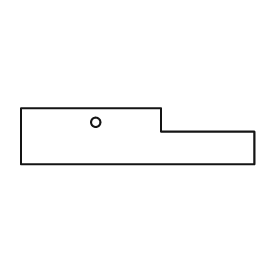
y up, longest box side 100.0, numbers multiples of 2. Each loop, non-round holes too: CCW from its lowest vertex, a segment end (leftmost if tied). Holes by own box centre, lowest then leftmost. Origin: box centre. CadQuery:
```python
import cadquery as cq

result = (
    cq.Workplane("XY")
    .moveTo(-50.0, -12.0)
    .lineTo(50.0, -12.0)
    .lineTo(50.0, 2.0)
    .lineTo(10.0, 2.0)
    .lineTo(10.0, 12.0)
    .lineTo(-50.0, 12.0)
    .close()
    .moveTo(-18.0, 6.0)
    .circle(2.0)
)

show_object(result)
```